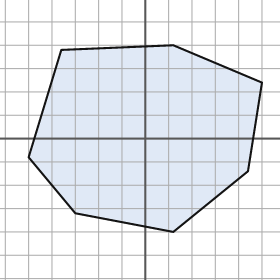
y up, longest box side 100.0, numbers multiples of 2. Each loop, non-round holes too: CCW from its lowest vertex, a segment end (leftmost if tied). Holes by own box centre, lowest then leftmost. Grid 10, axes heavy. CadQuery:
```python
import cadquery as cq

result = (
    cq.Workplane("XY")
    .moveTo(12.0, -40.0)
    .lineTo(44.0, -14.0)
    .lineTo(50.0, 24.0)
    .lineTo(12.0, 40.0)
    .lineTo(-36.0, 38.0)
    .lineTo(-50.0, -8.0)
    .lineTo(-30.0, -32.0)
    .close()
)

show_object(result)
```